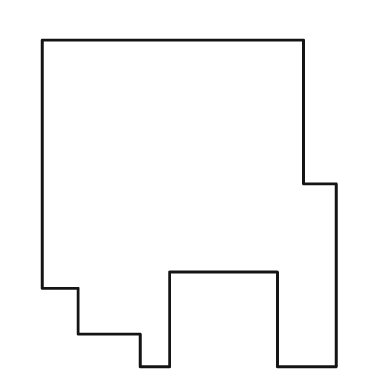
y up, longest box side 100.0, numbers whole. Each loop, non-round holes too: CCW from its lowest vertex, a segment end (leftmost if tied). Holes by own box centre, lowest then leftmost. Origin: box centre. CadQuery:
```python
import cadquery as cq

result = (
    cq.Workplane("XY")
    .moveTo(-15.0, -50.0)
    .lineTo(-6.0, -50.0)
    .lineTo(-6.0, -21.0)
    .lineTo(27.0, -21.0)
    .lineTo(27.0, -50.0)
    .lineTo(45.0, -50.0)
    .lineTo(45.0, 6.0)
    .lineTo(35.0, 6.0)
    .lineTo(35.0, 50.0)
    .lineTo(-45.0, 50.0)
    .lineTo(-45.0, -26.0)
    .lineTo(-34.0, -26.0)
    .lineTo(-34.0, -40.0)
    .lineTo(-15.0, -40.0)
    .close()
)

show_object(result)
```